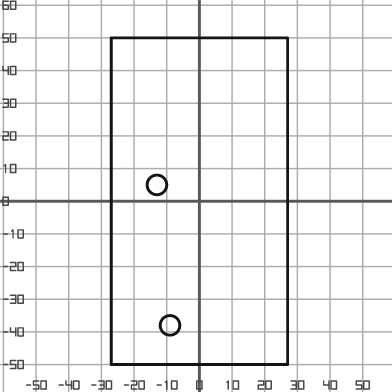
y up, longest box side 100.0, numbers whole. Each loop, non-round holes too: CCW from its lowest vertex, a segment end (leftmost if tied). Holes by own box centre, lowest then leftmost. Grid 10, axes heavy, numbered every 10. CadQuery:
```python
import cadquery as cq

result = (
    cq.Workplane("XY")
    .moveTo(-27.0, -50.0)
    .lineTo(27.0, -50.0)
    .lineTo(27.0, 50.0)
    .lineTo(-27.0, 50.0)
    .close()
    .moveTo(-9.0, -38.0)
    .circle(3.0)
    .moveTo(-13.0, 5.0)
    .circle(3.0)
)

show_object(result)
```